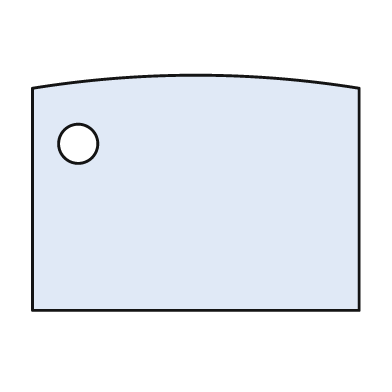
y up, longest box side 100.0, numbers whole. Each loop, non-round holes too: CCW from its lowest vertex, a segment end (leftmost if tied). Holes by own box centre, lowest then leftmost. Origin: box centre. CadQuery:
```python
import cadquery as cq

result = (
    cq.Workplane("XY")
    .moveTo(-50.0, -36.0)
    .lineTo(50.0, -36.0)
    .lineTo(50.0, 32.0)
    .threePointArc((0.0, 36.0), (-50.0, 32.0))
    .close()
    .moveTo(-36.0, 15.0)
    .circle(6.0)
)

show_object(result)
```